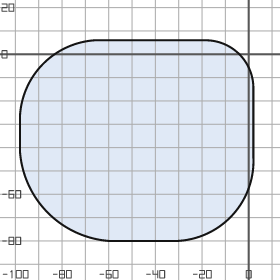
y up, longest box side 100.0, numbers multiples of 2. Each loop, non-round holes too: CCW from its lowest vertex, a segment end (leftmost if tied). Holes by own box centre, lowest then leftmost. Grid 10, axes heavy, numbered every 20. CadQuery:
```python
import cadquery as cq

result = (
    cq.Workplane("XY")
    .moveTo(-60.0, -80.0)
    .lineTo(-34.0, -80.0)
    .threePointArc((-8.0, -70.0), (2.0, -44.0))
    .lineTo(2.0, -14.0)
    .threePointArc((-4.0, 0.0), (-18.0, 6.0))
    .lineTo(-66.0, 6.0)
    .threePointArc((-88.0, -4.0), (-98.0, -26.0))
    .lineTo(-98.0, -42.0)
    .threePointArc((-86.0, -68.0), (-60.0, -80.0))
    .close()
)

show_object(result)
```